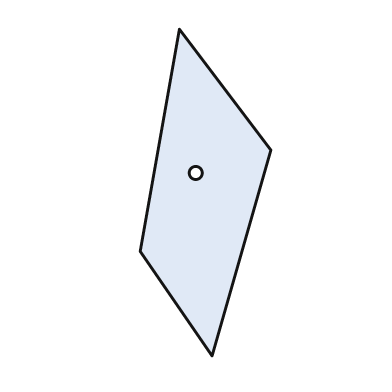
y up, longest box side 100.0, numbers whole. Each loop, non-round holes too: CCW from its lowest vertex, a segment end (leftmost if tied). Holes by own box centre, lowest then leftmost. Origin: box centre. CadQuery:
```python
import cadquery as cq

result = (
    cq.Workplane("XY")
    .moveTo(2.0, -50.0)
    .lineTo(20.0, 13.0)
    .lineTo(-8.0, 50.0)
    .lineTo(-20.0, -18.0)
    .close()
    .moveTo(-3.0, 6.0)
    .circle(2.0)
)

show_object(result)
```